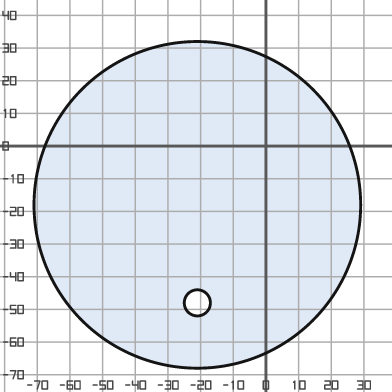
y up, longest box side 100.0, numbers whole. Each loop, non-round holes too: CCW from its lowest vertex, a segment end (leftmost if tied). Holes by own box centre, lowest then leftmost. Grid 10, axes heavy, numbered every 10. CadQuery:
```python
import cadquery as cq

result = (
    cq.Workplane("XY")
    .moveTo(-21.0, -18.0)
    .circle(50.0)
    .moveTo(-21.0, -48.0)
    .circle(4.0)
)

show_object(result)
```